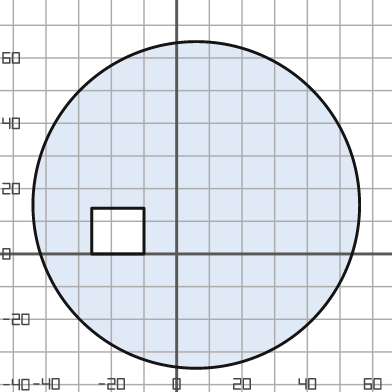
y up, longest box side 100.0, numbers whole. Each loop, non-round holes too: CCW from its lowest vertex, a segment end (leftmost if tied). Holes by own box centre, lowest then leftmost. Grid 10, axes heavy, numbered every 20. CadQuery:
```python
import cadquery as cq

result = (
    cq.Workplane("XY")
    .moveTo(6.0, 15.0)
    .circle(50.0)
    .moveTo(-26.0, 0.0)
    .lineTo(-10.0, 0.0)
    .lineTo(-10.0, 14.0)
    .lineTo(-26.0, 14.0)
    .close()
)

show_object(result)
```